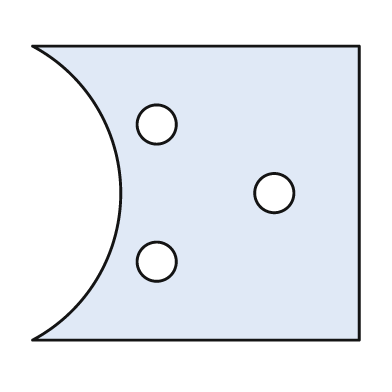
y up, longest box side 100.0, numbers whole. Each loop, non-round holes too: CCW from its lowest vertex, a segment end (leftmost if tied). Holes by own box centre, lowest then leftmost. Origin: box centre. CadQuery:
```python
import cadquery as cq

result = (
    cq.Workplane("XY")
    .moveTo(-50.0, -45.0)
    .lineTo(50.0, -45.0)
    .lineTo(50.0, 45.0)
    .lineTo(-50.0, 45.0)
    .threePointArc((-23.0, 0.0), (-50.0, -45.0))
    .close()
    .moveTo(-12.0, -21.0)
    .circle(6.0)
    .moveTo(24.0, 0.0)
    .circle(6.0)
    .moveTo(-12.0, 21.0)
    .circle(6.0)
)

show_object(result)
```